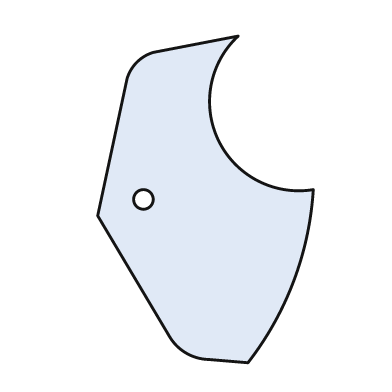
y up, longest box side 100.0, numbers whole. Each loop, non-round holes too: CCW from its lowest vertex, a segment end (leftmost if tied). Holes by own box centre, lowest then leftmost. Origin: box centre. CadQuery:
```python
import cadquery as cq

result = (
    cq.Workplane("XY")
    .moveTo(13.0, -50.0)
    .threePointArc((27.0, -25.0), (33.0, 3.0))
    .threePointArc((4.0, 18.0), (10.0, 50.0))
    .lineTo(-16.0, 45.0)
    .threePointArc((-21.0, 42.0), (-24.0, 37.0))
    .lineTo(-33.0, -5.0)
    .lineTo(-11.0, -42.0)
    .threePointArc((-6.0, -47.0), (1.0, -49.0))
    .close()
    .moveTo(-19.0, 0.0)
    .circle(3.0)
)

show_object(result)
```